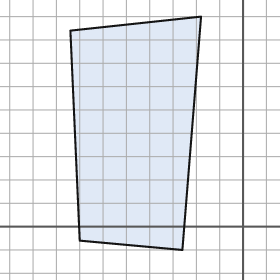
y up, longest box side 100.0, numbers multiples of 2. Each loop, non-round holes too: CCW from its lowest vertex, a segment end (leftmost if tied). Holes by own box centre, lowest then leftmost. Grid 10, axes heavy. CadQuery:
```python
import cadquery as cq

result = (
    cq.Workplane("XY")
    .moveTo(-26.0, -10.0)
    .lineTo(-18.0, 90.0)
    .lineTo(-74.0, 84.0)
    .lineTo(-70.0, -6.0)
    .close()
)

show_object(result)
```